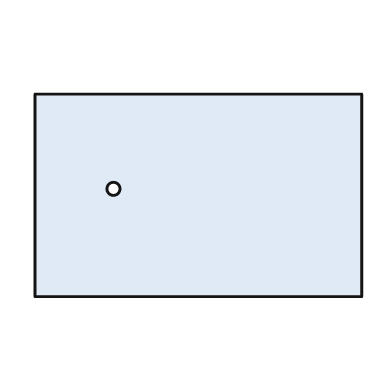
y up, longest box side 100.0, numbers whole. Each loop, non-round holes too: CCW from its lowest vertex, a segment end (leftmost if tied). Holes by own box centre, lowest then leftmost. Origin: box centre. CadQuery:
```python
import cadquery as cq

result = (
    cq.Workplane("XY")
    .moveTo(-50.0, -31.0)
    .lineTo(50.0, -31.0)
    .lineTo(50.0, 31.0)
    .lineTo(-50.0, 31.0)
    .close()
    .moveTo(-26.0, 2.0)
    .circle(2.0)
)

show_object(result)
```